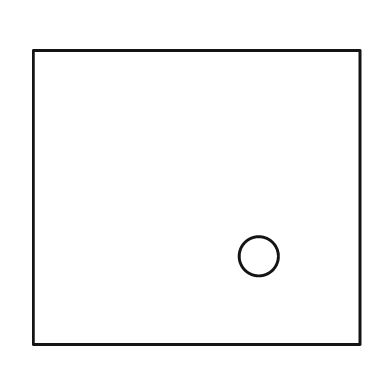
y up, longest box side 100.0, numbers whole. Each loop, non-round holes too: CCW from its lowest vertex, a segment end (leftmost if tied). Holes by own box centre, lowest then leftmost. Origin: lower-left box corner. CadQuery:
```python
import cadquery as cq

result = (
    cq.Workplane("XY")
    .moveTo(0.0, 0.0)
    .lineTo(100.0, 0.0)
    .lineTo(100.0, 90.0)
    .lineTo(0.0, 90.0)
    .close()
    .moveTo(69.0, 27.0)
    .circle(6.0)
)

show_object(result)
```